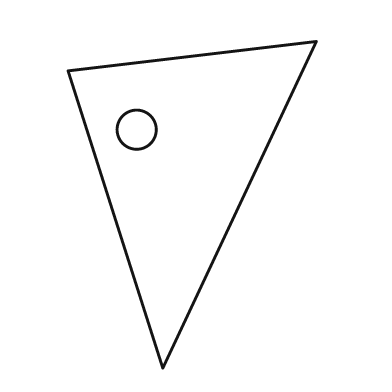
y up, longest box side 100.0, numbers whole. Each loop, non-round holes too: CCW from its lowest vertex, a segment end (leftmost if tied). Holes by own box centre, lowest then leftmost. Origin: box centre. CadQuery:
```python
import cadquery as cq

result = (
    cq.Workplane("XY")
    .moveTo(-9.0, -50.0)
    .lineTo(38.0, 50.0)
    .lineTo(-38.0, 41.0)
    .close()
    .moveTo(-17.0, 23.0)
    .circle(6.0)
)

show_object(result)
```